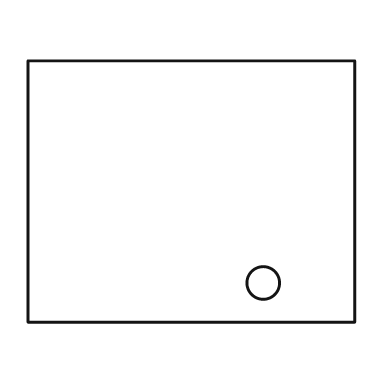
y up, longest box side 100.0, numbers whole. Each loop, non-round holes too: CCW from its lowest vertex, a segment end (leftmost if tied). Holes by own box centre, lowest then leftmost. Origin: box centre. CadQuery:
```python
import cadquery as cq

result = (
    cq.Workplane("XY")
    .moveTo(-50.0, -40.0)
    .lineTo(50.0, -40.0)
    .lineTo(50.0, 40.0)
    .lineTo(-50.0, 40.0)
    .close()
    .moveTo(22.0, -28.0)
    .circle(5.0)
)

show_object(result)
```